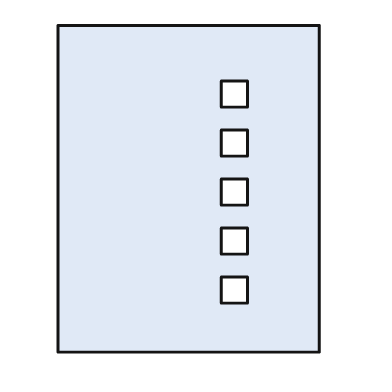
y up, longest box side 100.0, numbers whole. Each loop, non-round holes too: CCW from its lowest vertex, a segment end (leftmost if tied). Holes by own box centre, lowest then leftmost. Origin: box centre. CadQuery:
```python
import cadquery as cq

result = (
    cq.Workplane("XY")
    .moveTo(-40.0, -50.0)
    .lineTo(40.0, -50.0)
    .lineTo(40.0, 50.0)
    .lineTo(-40.0, 50.0)
    .close()
    .moveTo(10.0, -35.0)
    .lineTo(18.0, -35.0)
    .lineTo(18.0, -27.0)
    .lineTo(10.0, -27.0)
    .close()
    .moveTo(10.0, -20.0)
    .lineTo(18.0, -20.0)
    .lineTo(18.0, -12.0)
    .lineTo(10.0, -12.0)
    .close()
    .moveTo(10.0, -5.0)
    .lineTo(18.0, -5.0)
    .lineTo(18.0, 3.0)
    .lineTo(10.0, 3.0)
    .close()
    .moveTo(10.0, 10.0)
    .lineTo(18.0, 10.0)
    .lineTo(18.0, 18.0)
    .lineTo(10.0, 18.0)
    .close()
    .moveTo(10.0, 25.0)
    .lineTo(18.0, 25.0)
    .lineTo(18.0, 33.0)
    .lineTo(10.0, 33.0)
    .close()
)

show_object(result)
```